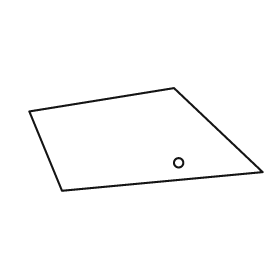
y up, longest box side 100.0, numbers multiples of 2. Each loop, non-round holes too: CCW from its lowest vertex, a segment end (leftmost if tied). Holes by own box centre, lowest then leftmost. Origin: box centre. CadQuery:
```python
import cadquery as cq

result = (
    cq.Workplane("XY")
    .moveTo(-36.0, -22.0)
    .lineTo(50.0, -14.0)
    .lineTo(12.0, 22.0)
    .lineTo(-50.0, 12.0)
    .close()
    .moveTo(14.0, -10.0)
    .circle(2.0)
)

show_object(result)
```